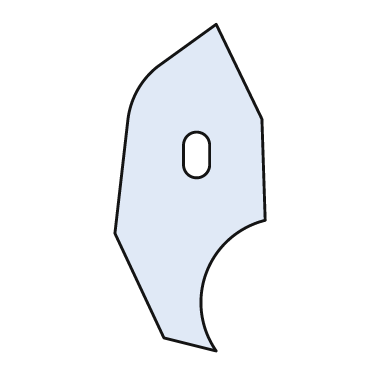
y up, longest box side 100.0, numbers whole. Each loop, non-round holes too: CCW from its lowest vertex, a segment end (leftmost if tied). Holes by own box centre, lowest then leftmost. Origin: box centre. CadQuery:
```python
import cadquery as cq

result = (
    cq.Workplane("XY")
    .moveTo(8.0, -50.0)
    .threePointArc((5.0, -26.0), (23.0, -10.0))
    .lineTo(22.0, 21.0)
    .lineTo(8.0, 50.0)
    .lineTo(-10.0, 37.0)
    .threePointArc((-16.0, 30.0), (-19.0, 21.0))
    .lineTo(-23.0, -14.0)
    .lineTo(-8.0, -46.0)
    .close()
    .moveTo(-2.0, 7.0)
    .threePointArc((2.0, 3.0), (6.0, 7.0))
    .lineTo(6.0, 13.0)
    .threePointArc((2.0, 17.0), (-2.0, 13.0))
    .close()
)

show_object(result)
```